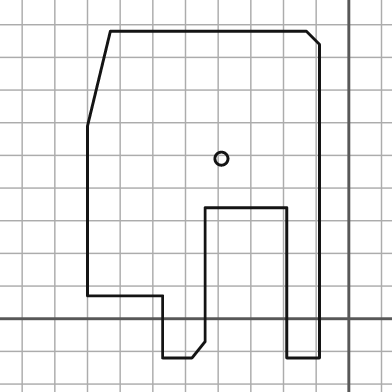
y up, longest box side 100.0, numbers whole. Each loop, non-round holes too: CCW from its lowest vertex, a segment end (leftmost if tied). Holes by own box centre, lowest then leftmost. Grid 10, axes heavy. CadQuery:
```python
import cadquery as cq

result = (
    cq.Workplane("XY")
    .moveTo(-57.0, -12.0)
    .lineTo(-48.0, -12.0)
    .lineTo(-44.0, -7.0)
    .lineTo(-44.0, 34.0)
    .lineTo(-19.0, 34.0)
    .lineTo(-19.0, -12.0)
    .lineTo(-9.0, -12.0)
    .lineTo(-9.0, 84.0)
    .lineTo(-13.0, 88.0)
    .lineTo(-73.0, 88.0)
    .lineTo(-80.0, 59.0)
    .lineTo(-80.0, 7.0)
    .lineTo(-57.0, 7.0)
    .close()
    .moveTo(-39.0, 49.0)
    .circle(2.0)
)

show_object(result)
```